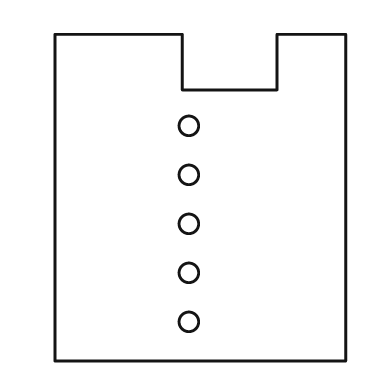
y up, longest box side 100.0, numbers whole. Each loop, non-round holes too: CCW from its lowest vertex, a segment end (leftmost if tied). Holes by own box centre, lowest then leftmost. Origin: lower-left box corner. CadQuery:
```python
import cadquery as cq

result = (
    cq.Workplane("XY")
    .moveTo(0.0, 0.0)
    .lineTo(89.0, 0.0)
    .lineTo(89.0, 100.0)
    .lineTo(68.0, 100.0)
    .lineTo(68.0, 83.0)
    .lineTo(39.0, 83.0)
    .lineTo(39.0, 100.0)
    .lineTo(0.0, 100.0)
    .close()
    .moveTo(41.0, 12.0)
    .circle(3.0)
    .moveTo(41.0, 27.0)
    .circle(3.0)
    .moveTo(41.0, 42.0)
    .circle(3.0)
    .moveTo(41.0, 57.0)
    .circle(3.0)
    .moveTo(41.0, 72.0)
    .circle(3.0)
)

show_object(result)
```